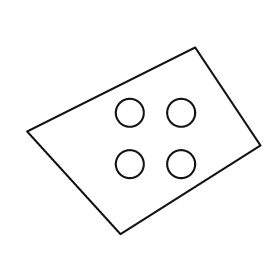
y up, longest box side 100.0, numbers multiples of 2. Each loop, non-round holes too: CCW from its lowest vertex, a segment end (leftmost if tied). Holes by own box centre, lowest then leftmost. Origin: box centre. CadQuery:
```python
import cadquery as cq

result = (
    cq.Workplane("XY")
    .moveTo(-10.0, -40.0)
    .lineTo(50.0, -2.0)
    .lineTo(22.0, 40.0)
    .lineTo(-50.0, 4.0)
    .close()
    .moveTo(-6.0, -10.0)
    .circle(6.0)
    .moveTo(16.0, -10.0)
    .circle(6.0)
    .moveTo(-6.0, 12.0)
    .circle(6.0)
    .moveTo(16.0, 12.0)
    .circle(6.0)
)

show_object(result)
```